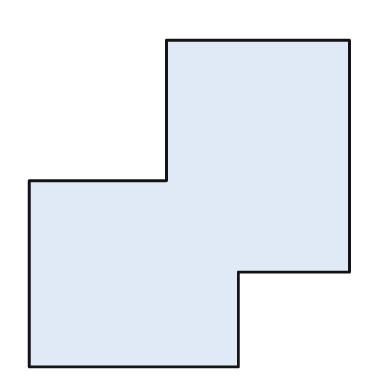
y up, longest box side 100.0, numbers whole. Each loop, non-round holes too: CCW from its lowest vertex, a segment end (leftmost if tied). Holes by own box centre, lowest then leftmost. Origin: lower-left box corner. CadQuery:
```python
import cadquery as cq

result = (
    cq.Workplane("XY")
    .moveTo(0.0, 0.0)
    .lineTo(64.0, 0.0)
    .lineTo(64.0, 29.0)
    .lineTo(98.0, 29.0)
    .lineTo(98.0, 100.0)
    .lineTo(42.0, 100.0)
    .lineTo(42.0, 57.0)
    .lineTo(0.0, 57.0)
    .close()
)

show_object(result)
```